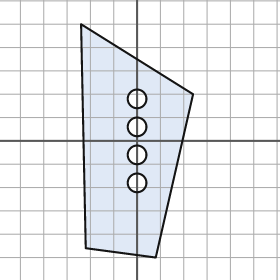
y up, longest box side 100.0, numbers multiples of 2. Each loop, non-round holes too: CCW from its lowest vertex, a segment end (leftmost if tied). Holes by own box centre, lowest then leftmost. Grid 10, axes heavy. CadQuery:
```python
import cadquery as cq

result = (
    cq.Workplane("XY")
    .moveTo(8.0, -50.0)
    .lineTo(24.0, 20.0)
    .lineTo(-24.0, 50.0)
    .lineTo(-22.0, -46.0)
    .close()
    .moveTo(0.0, -18.0)
    .circle(4.0)
    .moveTo(0.0, -6.0)
    .circle(4.0)
    .moveTo(0.0, 6.0)
    .circle(4.0)
    .moveTo(0.0, 18.0)
    .circle(4.0)
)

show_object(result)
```